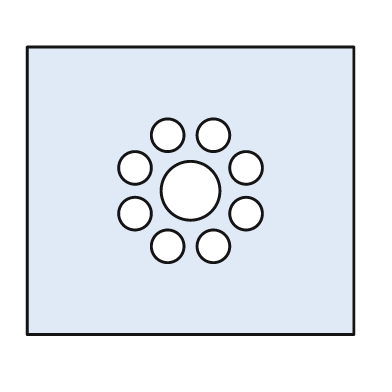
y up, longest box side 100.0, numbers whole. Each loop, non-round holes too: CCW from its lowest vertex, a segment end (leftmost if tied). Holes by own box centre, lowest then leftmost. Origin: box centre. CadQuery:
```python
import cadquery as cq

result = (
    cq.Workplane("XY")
    .moveTo(-50.0, -44.0)
    .lineTo(50.0, -44.0)
    .lineTo(50.0, 44.0)
    .lineTo(-50.0, 44.0)
    .close()
    .moveTo(-7.0, -17.0)
    .circle(5.0)
    .moveTo(7.0, -17.0)
    .circle(5.0)
    .moveTo(-17.0, -7.0)
    .circle(5.0)
    .moveTo(17.0, -7.0)
    .circle(5.0)
    .moveTo(0.0, 0.0)
    .circle(9.0)
    .moveTo(-17.0, 7.0)
    .circle(5.0)
    .moveTo(17.0, 7.0)
    .circle(5.0)
    .moveTo(-7.0, 17.0)
    .circle(5.0)
    .moveTo(7.0, 17.0)
    .circle(5.0)
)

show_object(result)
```